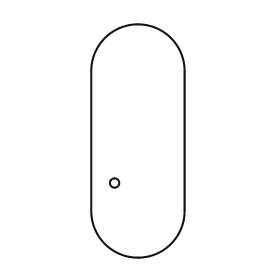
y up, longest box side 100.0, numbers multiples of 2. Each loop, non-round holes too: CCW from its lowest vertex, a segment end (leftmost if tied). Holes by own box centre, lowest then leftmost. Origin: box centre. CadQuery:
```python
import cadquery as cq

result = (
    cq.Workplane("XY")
    .moveTo(-20.0, -30.0)
    .threePointArc((0.0, -50.0), (20.0, -30.0))
    .lineTo(20.0, 30.0)
    .threePointArc((0.0, 50.0), (-20.0, 30.0))
    .close()
    .moveTo(-10.0, -18.0)
    .circle(2.0)
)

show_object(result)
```